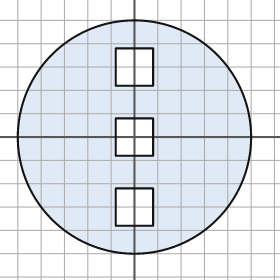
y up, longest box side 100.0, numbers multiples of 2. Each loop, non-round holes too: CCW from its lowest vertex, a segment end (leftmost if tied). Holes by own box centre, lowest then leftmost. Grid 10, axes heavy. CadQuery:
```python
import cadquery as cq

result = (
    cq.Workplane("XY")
    .moveTo(0.0, 0.0)
    .circle(50.0)
    .moveTo(-8.0, -38.0)
    .lineTo(8.0, -38.0)
    .lineTo(8.0, -22.0)
    .lineTo(-8.0, -22.0)
    .close()
    .moveTo(-8.0, -8.0)
    .lineTo(8.0, -8.0)
    .lineTo(8.0, 8.0)
    .lineTo(-8.0, 8.0)
    .close()
    .moveTo(-8.0, 22.0)
    .lineTo(8.0, 22.0)
    .lineTo(8.0, 38.0)
    .lineTo(-8.0, 38.0)
    .close()
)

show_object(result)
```